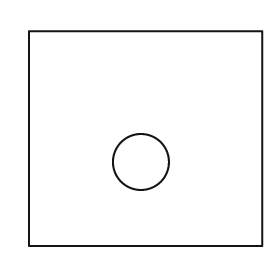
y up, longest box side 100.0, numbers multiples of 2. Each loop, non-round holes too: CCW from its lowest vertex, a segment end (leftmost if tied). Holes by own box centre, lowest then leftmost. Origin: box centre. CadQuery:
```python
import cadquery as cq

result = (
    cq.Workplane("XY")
    .moveTo(-50.0, -46.0)
    .lineTo(50.0, -46.0)
    .lineTo(50.0, 46.0)
    .lineTo(-50.0, 46.0)
    .close()
    .moveTo(-2.0, -10.0)
    .circle(12.0)
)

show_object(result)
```